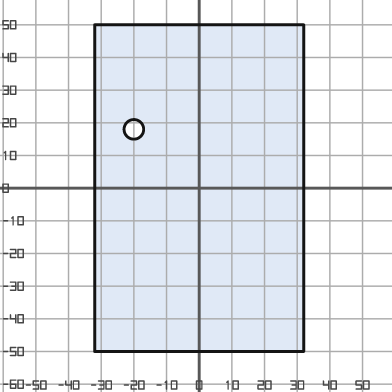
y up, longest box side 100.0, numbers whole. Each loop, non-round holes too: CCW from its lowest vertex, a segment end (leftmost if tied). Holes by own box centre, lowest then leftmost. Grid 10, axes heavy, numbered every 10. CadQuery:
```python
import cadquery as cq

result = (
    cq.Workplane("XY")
    .moveTo(-32.0, -50.0)
    .lineTo(32.0, -50.0)
    .lineTo(32.0, 50.0)
    .lineTo(-32.0, 50.0)
    .close()
    .moveTo(-20.0, 18.0)
    .circle(3.0)
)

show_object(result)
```